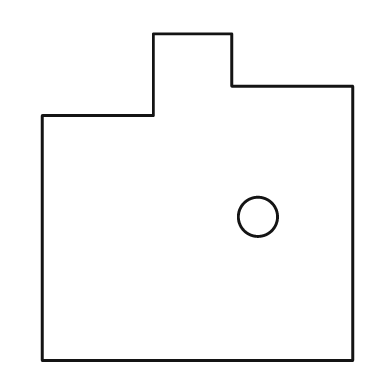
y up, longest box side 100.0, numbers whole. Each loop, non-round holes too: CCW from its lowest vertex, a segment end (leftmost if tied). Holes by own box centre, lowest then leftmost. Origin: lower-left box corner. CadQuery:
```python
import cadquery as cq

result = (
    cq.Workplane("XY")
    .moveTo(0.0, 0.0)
    .lineTo(95.0, 0.0)
    .lineTo(95.0, 84.0)
    .lineTo(58.0, 84.0)
    .lineTo(58.0, 100.0)
    .lineTo(34.0, 100.0)
    .lineTo(34.0, 75.0)
    .lineTo(0.0, 75.0)
    .close()
    .moveTo(66.0, 44.0)
    .circle(6.0)
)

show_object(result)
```